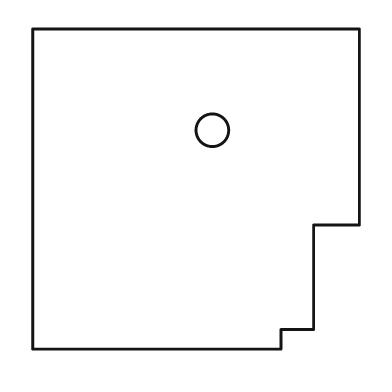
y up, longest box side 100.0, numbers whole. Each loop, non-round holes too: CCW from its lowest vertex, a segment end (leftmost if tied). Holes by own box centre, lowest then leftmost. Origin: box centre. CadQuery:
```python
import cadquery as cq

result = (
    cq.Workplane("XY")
    .moveTo(-50.0, -49.0)
    .lineTo(26.0, -49.0)
    .lineTo(26.0, -43.0)
    .lineTo(36.0, -43.0)
    .lineTo(36.0, -11.0)
    .lineTo(50.0, -11.0)
    .lineTo(50.0, 49.0)
    .lineTo(-50.0, 49.0)
    .close()
    .moveTo(5.0, 18.0)
    .circle(5.0)
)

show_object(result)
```